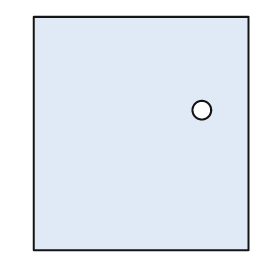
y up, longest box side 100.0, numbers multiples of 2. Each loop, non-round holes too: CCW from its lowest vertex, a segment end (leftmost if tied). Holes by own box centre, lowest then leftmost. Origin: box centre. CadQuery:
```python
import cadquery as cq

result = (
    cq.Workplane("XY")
    .moveTo(-46.0, -50.0)
    .lineTo(46.0, -50.0)
    .lineTo(46.0, 50.0)
    .lineTo(-46.0, 50.0)
    .close()
    .moveTo(26.0, 10.0)
    .circle(4.0)
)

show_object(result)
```